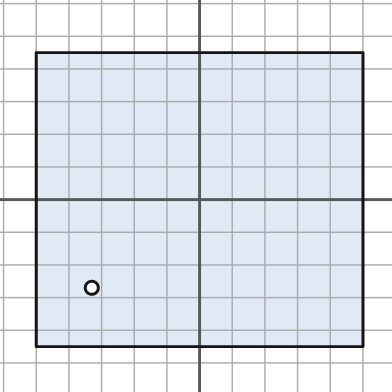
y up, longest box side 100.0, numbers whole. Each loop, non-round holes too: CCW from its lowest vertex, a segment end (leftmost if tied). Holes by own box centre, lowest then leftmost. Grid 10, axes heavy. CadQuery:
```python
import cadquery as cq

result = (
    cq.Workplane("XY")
    .moveTo(-50.0, -45.0)
    .lineTo(50.0, -45.0)
    .lineTo(50.0, 45.0)
    .lineTo(-50.0, 45.0)
    .close()
    .moveTo(-33.0, -27.0)
    .circle(2.0)
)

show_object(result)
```